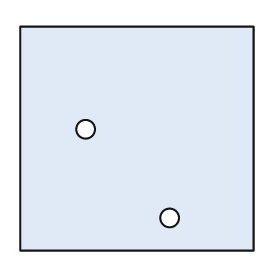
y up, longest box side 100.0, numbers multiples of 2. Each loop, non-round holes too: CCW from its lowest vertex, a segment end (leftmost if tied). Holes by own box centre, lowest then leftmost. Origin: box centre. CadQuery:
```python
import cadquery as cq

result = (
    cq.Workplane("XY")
    .moveTo(-50.0, -48.0)
    .lineTo(50.0, -48.0)
    .lineTo(50.0, 48.0)
    .lineTo(-50.0, 48.0)
    .close()
    .moveTo(14.0, -34.0)
    .circle(4.0)
    .moveTo(-22.0, 4.0)
    .circle(4.0)
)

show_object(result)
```